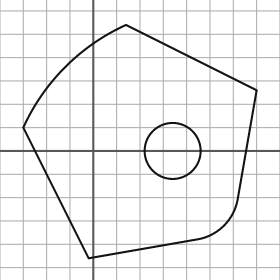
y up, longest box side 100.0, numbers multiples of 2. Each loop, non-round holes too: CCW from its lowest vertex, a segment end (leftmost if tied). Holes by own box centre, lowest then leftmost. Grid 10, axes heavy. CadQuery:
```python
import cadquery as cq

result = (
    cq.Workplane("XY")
    .moveTo(-2.0, -46.0)
    .lineTo(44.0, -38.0)
    .threePointArc((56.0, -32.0), (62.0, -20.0))
    .lineTo(70.0, 26.0)
    .lineTo(14.0, 54.0)
    .threePointArc((-12.0, 36.0), (-30.0, 10.0))
    .close()
    .moveTo(34.0, 0.0)
    .circle(12.0)
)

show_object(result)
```